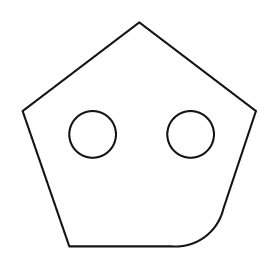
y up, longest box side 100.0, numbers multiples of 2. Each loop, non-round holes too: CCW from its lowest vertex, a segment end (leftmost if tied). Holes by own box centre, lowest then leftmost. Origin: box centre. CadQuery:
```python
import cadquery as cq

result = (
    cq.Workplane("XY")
    .moveTo(-30.0, -48.0)
    .lineTo(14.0, -48.0)
    .threePointArc((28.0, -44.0), (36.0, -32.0))
    .lineTo(50.0, 10.0)
    .lineTo(0.0, 48.0)
    .lineTo(-50.0, 10.0)
    .close()
    .moveTo(-20.0, 0.0)
    .circle(10.0)
    .moveTo(22.0, 0.0)
    .circle(10.0)
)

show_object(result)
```